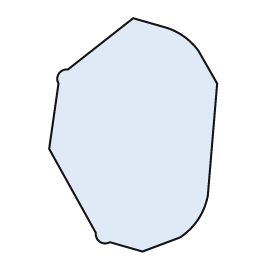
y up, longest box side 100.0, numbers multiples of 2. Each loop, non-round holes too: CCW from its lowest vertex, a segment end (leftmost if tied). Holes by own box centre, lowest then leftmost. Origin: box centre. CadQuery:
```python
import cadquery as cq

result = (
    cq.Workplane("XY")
    .moveTo(4.0, -50.0)
    .lineTo(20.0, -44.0)
    .threePointArc((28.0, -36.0), (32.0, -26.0))
    .lineTo(36.0, 22.0)
    .lineTo(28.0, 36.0)
    .threePointArc((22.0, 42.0), (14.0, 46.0))
    .lineTo(0.0, 50.0)
    .lineTo(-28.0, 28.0)
    .threePointArc((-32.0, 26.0), (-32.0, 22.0))
    .lineTo(-36.0, -6.0)
    .lineTo(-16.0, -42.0)
    .threePointArc((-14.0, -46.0), (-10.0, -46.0))
    .close()
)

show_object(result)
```